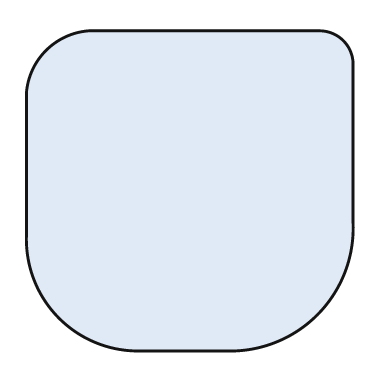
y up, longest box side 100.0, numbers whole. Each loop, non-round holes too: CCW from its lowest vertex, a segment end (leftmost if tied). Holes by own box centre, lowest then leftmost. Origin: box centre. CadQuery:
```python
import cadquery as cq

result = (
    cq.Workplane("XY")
    .moveTo(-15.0, -49.0)
    .lineTo(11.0, -49.0)
    .threePointArc((39.0, -38.0), (50.0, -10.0))
    .lineTo(50.0, 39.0)
    .threePointArc((47.0, 46.0), (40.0, 49.0))
    .lineTo(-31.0, 49.0)
    .threePointArc((-44.0, 43.0), (-50.0, 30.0))
    .lineTo(-50.0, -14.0)
    .threePointArc((-40.0, -39.0), (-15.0, -49.0))
    .close()
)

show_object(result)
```